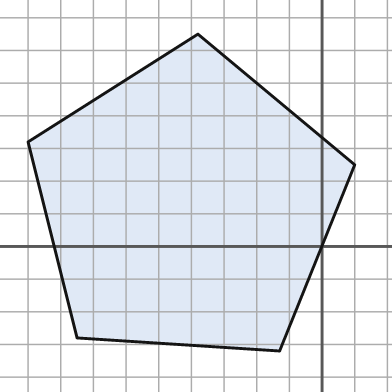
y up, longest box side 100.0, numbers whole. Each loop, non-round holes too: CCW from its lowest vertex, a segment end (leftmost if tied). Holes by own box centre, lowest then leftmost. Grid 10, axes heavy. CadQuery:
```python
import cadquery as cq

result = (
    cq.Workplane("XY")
    .moveTo(-13.0, -32.0)
    .lineTo(10.0, 25.0)
    .lineTo(-38.0, 65.0)
    .lineTo(-90.0, 32.0)
    .lineTo(-75.0, -28.0)
    .close()
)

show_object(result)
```